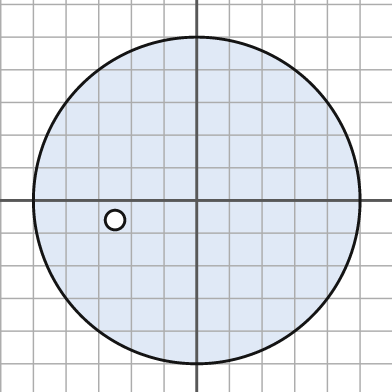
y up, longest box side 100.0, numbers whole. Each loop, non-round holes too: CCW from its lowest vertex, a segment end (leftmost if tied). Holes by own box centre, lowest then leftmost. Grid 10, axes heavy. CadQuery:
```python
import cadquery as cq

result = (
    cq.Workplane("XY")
    .moveTo(0.0, 0.0)
    .circle(50.0)
    .moveTo(-25.0, -6.0)
    .circle(3.0)
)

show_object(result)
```